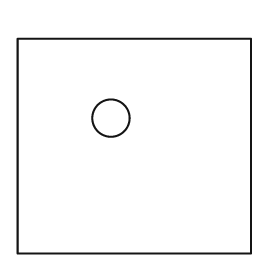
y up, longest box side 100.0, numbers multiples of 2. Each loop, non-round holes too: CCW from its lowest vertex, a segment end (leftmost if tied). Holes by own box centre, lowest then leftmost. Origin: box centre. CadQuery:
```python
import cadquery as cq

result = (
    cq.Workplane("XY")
    .moveTo(-50.0, -46.0)
    .lineTo(50.0, -46.0)
    .lineTo(50.0, 46.0)
    .lineTo(-50.0, 46.0)
    .close()
    .moveTo(-10.0, 12.0)
    .circle(8.0)
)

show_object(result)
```